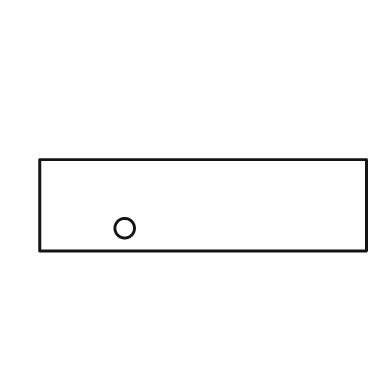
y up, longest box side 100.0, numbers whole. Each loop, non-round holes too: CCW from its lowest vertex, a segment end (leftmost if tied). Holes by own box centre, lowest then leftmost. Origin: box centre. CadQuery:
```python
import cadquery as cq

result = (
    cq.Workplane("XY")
    .moveTo(-50.0, -14.0)
    .lineTo(50.0, -14.0)
    .lineTo(50.0, 14.0)
    .lineTo(-50.0, 14.0)
    .close()
    .moveTo(-24.0, -7.0)
    .circle(3.0)
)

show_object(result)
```